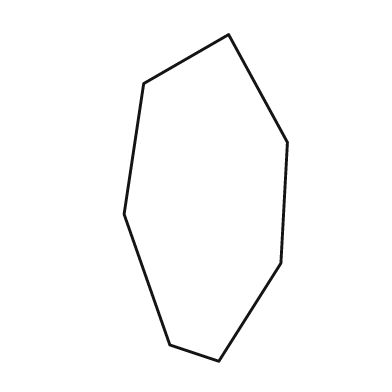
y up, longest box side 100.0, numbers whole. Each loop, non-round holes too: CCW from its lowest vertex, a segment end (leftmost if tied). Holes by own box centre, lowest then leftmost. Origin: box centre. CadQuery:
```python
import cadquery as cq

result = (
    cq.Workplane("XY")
    .moveTo(4.0, -50.0)
    .lineTo(23.0, -20.0)
    .lineTo(25.0, 17.0)
    .lineTo(7.0, 50.0)
    .lineTo(-19.0, 35.0)
    .lineTo(-25.0, -5.0)
    .lineTo(-11.0, -45.0)
    .close()
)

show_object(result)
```